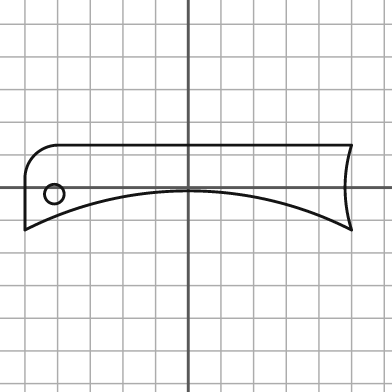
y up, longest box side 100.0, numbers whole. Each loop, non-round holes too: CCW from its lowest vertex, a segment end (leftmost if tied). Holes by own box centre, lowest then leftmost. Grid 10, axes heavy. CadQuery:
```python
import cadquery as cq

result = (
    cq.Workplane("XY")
    .moveTo(-50.0, -13.0)
    .threePointArc((0.0, -1.0), (50.0, -13.0))
    .threePointArc((48.0, 0.0), (50.0, 13.0))
    .lineTo(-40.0, 13.0)
    .threePointArc((-47.0, 10.0), (-50.0, 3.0))
    .close()
    .moveTo(-41.0, -2.0)
    .circle(3.0)
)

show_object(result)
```